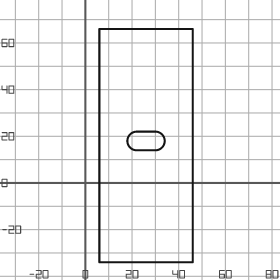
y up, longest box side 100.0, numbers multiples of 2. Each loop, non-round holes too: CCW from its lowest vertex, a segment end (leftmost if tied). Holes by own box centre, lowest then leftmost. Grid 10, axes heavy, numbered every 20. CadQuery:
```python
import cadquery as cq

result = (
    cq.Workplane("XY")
    .moveTo(6.0, -34.0)
    .lineTo(46.0, -34.0)
    .lineTo(46.0, 66.0)
    .lineTo(6.0, 66.0)
    .close()
    .moveTo(22.0, 14.0)
    .lineTo(30.0, 14.0)
    .threePointArc((34.0, 18.0), (30.0, 22.0))
    .lineTo(22.0, 22.0)
    .threePointArc((18.0, 18.0), (22.0, 14.0))
    .close()
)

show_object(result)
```